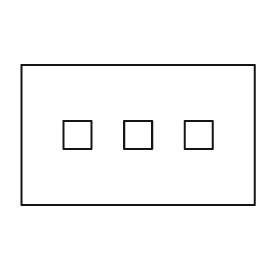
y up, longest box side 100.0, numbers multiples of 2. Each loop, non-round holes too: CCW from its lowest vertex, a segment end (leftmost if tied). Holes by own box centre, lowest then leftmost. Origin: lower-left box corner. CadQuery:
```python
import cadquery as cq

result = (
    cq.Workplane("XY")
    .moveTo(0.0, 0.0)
    .lineTo(100.0, 0.0)
    .lineTo(100.0, 60.0)
    .lineTo(0.0, 60.0)
    .close()
    .moveTo(18.0, 24.0)
    .lineTo(30.0, 24.0)
    .lineTo(30.0, 36.0)
    .lineTo(18.0, 36.0)
    .close()
    .moveTo(44.0, 24.0)
    .lineTo(56.0, 24.0)
    .lineTo(56.0, 36.0)
    .lineTo(44.0, 36.0)
    .close()
    .moveTo(70.0, 24.0)
    .lineTo(82.0, 24.0)
    .lineTo(82.0, 36.0)
    .lineTo(70.0, 36.0)
    .close()
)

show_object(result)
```